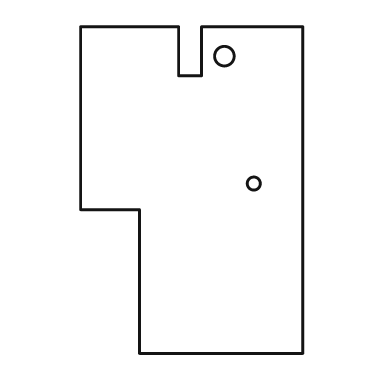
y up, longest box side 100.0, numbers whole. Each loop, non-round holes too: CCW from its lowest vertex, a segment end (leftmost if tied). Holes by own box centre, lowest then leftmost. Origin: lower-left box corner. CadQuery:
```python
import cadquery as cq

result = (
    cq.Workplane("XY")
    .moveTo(18.0, 0.0)
    .lineTo(68.0, 0.0)
    .lineTo(68.0, 100.0)
    .lineTo(37.0, 100.0)
    .lineTo(37.0, 85.0)
    .lineTo(30.0, 85.0)
    .lineTo(30.0, 100.0)
    .lineTo(0.0, 100.0)
    .lineTo(0.0, 44.0)
    .lineTo(18.0, 44.0)
    .close()
    .moveTo(53.0, 52.0)
    .circle(2.0)
    .moveTo(44.0, 91.0)
    .circle(3.0)
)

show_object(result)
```